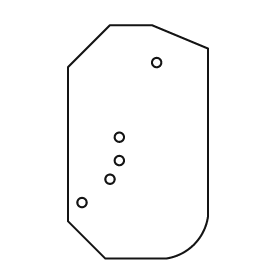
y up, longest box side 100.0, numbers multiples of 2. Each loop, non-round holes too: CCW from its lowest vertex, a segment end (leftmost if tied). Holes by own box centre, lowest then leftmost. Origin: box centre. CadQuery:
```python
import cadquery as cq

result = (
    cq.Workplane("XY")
    .moveTo(-14.0, -50.0)
    .lineTo(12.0, -50.0)
    .threePointArc((24.0, -44.0), (30.0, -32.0))
    .lineTo(30.0, 40.0)
    .lineTo(6.0, 50.0)
    .lineTo(-12.0, 50.0)
    .lineTo(-30.0, 32.0)
    .lineTo(-30.0, -34.0)
    .close()
    .moveTo(-24.0, -26.0)
    .circle(2.0)
    .moveTo(-12.0, -16.0)
    .circle(2.0)
    .moveTo(-8.0, -8.0)
    .circle(2.0)
    .moveTo(-8.0, 2.0)
    .circle(2.0)
    .moveTo(8.0, 34.0)
    .circle(2.0)
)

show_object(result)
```